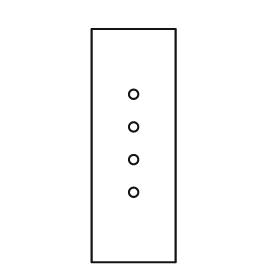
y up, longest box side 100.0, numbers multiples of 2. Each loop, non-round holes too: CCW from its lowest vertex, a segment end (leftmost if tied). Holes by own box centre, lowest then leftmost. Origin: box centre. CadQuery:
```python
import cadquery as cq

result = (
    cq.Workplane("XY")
    .moveTo(-18.0, -50.0)
    .lineTo(18.0, -50.0)
    .lineTo(18.0, 50.0)
    .lineTo(-18.0, 50.0)
    .close()
    .moveTo(0.0, -20.0)
    .circle(2.0)
    .moveTo(0.0, -6.0)
    .circle(2.0)
    .moveTo(0.0, 8.0)
    .circle(2.0)
    .moveTo(0.0, 22.0)
    .circle(2.0)
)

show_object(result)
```